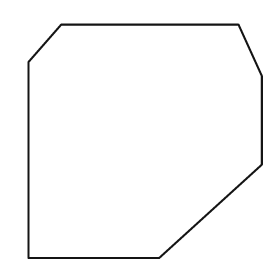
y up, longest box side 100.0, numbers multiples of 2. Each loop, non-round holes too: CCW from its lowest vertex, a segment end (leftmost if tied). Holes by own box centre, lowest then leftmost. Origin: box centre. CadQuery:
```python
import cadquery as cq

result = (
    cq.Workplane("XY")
    .moveTo(-50.0, -50.0)
    .lineTo(6.0, -50.0)
    .lineTo(50.0, -10.0)
    .lineTo(50.0, 28.0)
    .lineTo(40.0, 50.0)
    .lineTo(-36.0, 50.0)
    .lineTo(-50.0, 34.0)
    .close()
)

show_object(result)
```